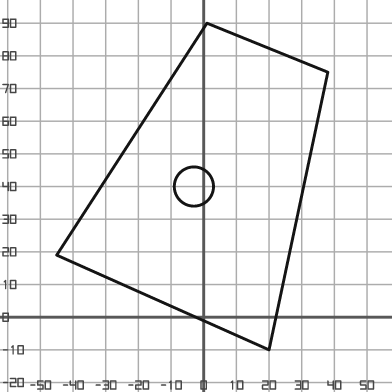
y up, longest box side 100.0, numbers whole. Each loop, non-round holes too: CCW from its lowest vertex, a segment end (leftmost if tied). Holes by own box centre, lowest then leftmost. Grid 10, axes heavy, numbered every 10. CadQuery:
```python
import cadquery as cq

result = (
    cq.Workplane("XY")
    .moveTo(20.0, -10.0)
    .lineTo(38.0, 75.0)
    .lineTo(1.0, 90.0)
    .lineTo(-45.0, 19.0)
    .close()
    .moveTo(-3.0, 40.0)
    .circle(6.0)
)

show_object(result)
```